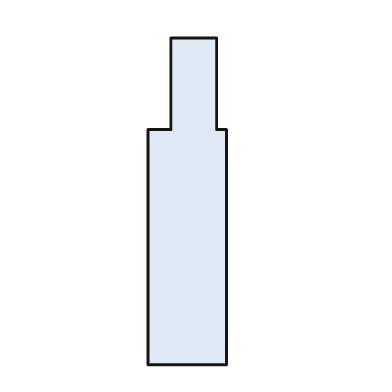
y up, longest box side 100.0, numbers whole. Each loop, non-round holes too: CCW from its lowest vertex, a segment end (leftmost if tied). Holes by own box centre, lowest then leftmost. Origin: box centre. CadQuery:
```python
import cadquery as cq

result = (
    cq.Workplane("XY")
    .moveTo(-12.0, -50.0)
    .lineTo(12.0, -50.0)
    .lineTo(12.0, 22.0)
    .lineTo(9.0, 22.0)
    .lineTo(9.0, 50.0)
    .lineTo(-5.0, 50.0)
    .lineTo(-5.0, 22.0)
    .lineTo(-12.0, 22.0)
    .close()
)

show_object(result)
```